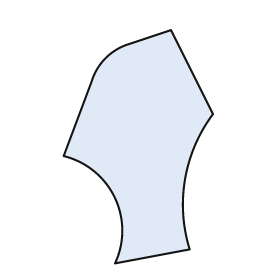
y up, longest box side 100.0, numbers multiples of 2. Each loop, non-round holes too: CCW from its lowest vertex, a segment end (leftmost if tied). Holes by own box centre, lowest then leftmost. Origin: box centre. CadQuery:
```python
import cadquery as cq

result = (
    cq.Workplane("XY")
    .moveTo(-10.0, -50.0)
    .lineTo(22.0, -44.0)
    .threePointArc((20.0, -14.0), (32.0, 14.0))
    .lineTo(14.0, 50.0)
    .lineTo(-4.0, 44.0)
    .threePointArc((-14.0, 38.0), (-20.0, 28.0))
    .lineTo(-32.0, -4.0)
    .threePointArc((-10.0, -22.0), (-10.0, -50.0))
    .close()
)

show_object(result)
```